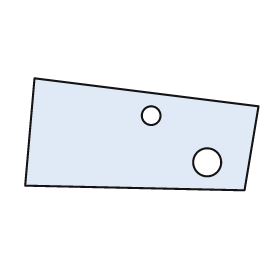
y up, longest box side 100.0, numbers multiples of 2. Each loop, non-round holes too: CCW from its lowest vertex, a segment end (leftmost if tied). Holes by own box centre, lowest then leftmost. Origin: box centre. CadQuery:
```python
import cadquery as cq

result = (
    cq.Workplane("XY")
    .moveTo(44.0, -24.0)
    .lineTo(50.0, 12.0)
    .lineTo(-46.0, 24.0)
    .lineTo(-50.0, -22.0)
    .close()
    .moveTo(28.0, -12.0)
    .circle(6.0)
    .moveTo(4.0, 8.0)
    .circle(4.0)
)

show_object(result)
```